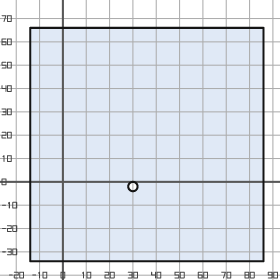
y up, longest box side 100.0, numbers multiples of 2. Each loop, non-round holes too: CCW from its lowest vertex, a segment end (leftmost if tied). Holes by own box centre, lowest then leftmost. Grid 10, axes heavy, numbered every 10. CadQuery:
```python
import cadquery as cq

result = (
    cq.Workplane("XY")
    .moveTo(-14.0, -34.0)
    .lineTo(86.0, -34.0)
    .lineTo(86.0, 66.0)
    .lineTo(-14.0, 66.0)
    .close()
    .moveTo(30.0, -2.0)
    .circle(2.0)
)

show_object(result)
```